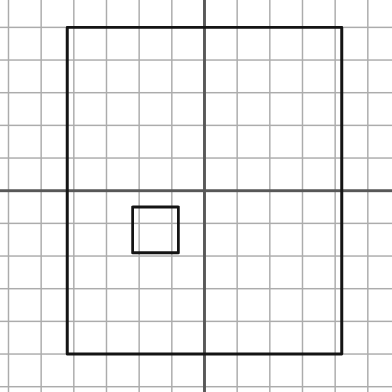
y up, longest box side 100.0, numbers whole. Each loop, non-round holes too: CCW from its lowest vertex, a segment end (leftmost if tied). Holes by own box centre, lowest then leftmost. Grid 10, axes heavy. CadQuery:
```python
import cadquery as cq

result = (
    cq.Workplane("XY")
    .moveTo(-42.0, -50.0)
    .lineTo(42.0, -50.0)
    .lineTo(42.0, 50.0)
    .lineTo(-42.0, 50.0)
    .close()
    .moveTo(-22.0, -19.0)
    .lineTo(-8.0, -19.0)
    .lineTo(-8.0, -5.0)
    .lineTo(-22.0, -5.0)
    .close()
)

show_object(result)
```